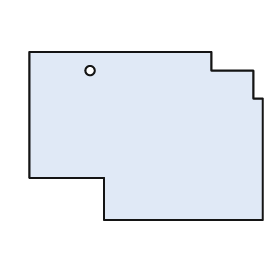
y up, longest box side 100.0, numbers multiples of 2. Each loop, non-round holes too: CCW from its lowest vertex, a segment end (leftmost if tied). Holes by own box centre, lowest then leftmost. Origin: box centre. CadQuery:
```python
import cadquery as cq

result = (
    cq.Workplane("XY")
    .moveTo(-18.0, -36.0)
    .lineTo(50.0, -36.0)
    .lineTo(50.0, 16.0)
    .lineTo(46.0, 16.0)
    .lineTo(46.0, 28.0)
    .lineTo(28.0, 28.0)
    .lineTo(28.0, 36.0)
    .lineTo(-50.0, 36.0)
    .lineTo(-50.0, -18.0)
    .lineTo(-18.0, -18.0)
    .close()
    .moveTo(-24.0, 28.0)
    .circle(2.0)
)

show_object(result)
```